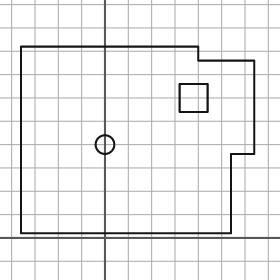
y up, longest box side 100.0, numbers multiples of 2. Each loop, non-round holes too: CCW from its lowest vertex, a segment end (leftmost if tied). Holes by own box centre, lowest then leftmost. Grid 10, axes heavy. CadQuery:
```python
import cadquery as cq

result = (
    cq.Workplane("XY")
    .moveTo(-36.0, 2.0)
    .lineTo(54.0, 2.0)
    .lineTo(54.0, 36.0)
    .lineTo(64.0, 36.0)
    .lineTo(64.0, 76.0)
    .lineTo(40.0, 76.0)
    .lineTo(40.0, 82.0)
    .lineTo(-36.0, 82.0)
    .close()
    .moveTo(0.0, 40.0)
    .circle(4.0)
    .moveTo(32.0, 54.0)
    .lineTo(44.0, 54.0)
    .lineTo(44.0, 66.0)
    .lineTo(32.0, 66.0)
    .close()
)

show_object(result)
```